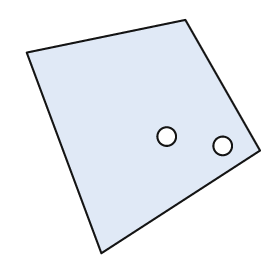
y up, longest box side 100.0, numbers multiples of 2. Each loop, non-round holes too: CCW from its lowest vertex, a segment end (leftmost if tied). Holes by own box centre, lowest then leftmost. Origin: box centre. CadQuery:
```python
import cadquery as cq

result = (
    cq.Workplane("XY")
    .moveTo(-18.0, -50.0)
    .lineTo(50.0, -6.0)
    .lineTo(18.0, 50.0)
    .lineTo(-50.0, 36.0)
    .close()
    .moveTo(34.0, -4.0)
    .circle(4.0)
    .moveTo(10.0, 0.0)
    .circle(4.0)
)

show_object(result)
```